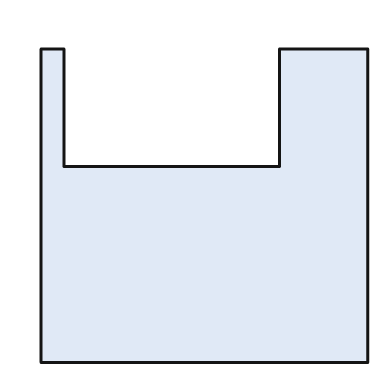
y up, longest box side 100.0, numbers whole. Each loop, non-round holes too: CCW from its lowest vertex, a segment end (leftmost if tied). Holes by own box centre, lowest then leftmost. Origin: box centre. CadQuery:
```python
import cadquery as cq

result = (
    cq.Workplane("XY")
    .moveTo(-50.0, -48.0)
    .lineTo(50.0, -48.0)
    .lineTo(50.0, 48.0)
    .lineTo(23.0, 48.0)
    .lineTo(23.0, 12.0)
    .lineTo(-43.0, 12.0)
    .lineTo(-43.0, 48.0)
    .lineTo(-50.0, 48.0)
    .close()
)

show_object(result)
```